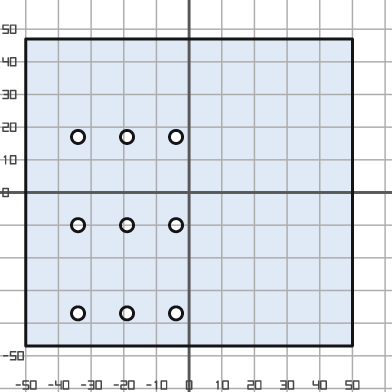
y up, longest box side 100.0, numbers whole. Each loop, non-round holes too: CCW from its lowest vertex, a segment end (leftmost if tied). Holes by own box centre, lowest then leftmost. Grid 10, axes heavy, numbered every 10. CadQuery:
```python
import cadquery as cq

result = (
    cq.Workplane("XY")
    .moveTo(-50.0, -47.0)
    .lineTo(50.0, -47.0)
    .lineTo(50.0, 47.0)
    .lineTo(-50.0, 47.0)
    .close()
    .moveTo(-34.0, -37.0)
    .circle(2.0)
    .moveTo(-19.0, -37.0)
    .circle(2.0)
    .moveTo(-4.0, -37.0)
    .circle(2.0)
    .moveTo(-34.0, -10.0)
    .circle(2.0)
    .moveTo(-19.0, -10.0)
    .circle(2.0)
    .moveTo(-4.0, -10.0)
    .circle(2.0)
    .moveTo(-34.0, 17.0)
    .circle(2.0)
    .moveTo(-19.0, 17.0)
    .circle(2.0)
    .moveTo(-4.0, 17.0)
    .circle(2.0)
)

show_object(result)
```